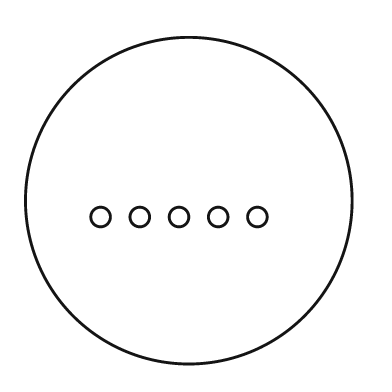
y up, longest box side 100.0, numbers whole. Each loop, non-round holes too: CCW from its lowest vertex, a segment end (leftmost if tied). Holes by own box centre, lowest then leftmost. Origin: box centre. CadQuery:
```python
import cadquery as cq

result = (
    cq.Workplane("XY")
    .moveTo(0.0, 0.0)
    .circle(50.0)
    .moveTo(-27.0, -5.0)
    .circle(3.0)
    .moveTo(-15.0, -5.0)
    .circle(3.0)
    .moveTo(-3.0, -5.0)
    .circle(3.0)
    .moveTo(9.0, -5.0)
    .circle(3.0)
    .moveTo(21.0, -5.0)
    .circle(3.0)
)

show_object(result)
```